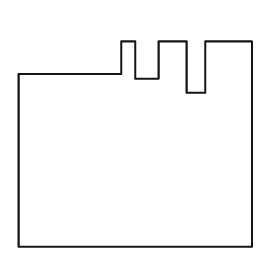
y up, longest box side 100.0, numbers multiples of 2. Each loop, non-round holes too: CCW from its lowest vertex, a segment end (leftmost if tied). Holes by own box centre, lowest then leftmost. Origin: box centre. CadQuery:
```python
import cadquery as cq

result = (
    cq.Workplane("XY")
    .moveTo(-50.0, -44.0)
    .lineTo(50.0, -44.0)
    .lineTo(50.0, 44.0)
    .lineTo(30.0, 44.0)
    .lineTo(30.0, 22.0)
    .lineTo(22.0, 22.0)
    .lineTo(22.0, 44.0)
    .lineTo(10.0, 44.0)
    .lineTo(10.0, 28.0)
    .lineTo(0.0, 28.0)
    .lineTo(0.0, 44.0)
    .lineTo(-6.0, 44.0)
    .lineTo(-6.0, 30.0)
    .lineTo(-50.0, 30.0)
    .close()
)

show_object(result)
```